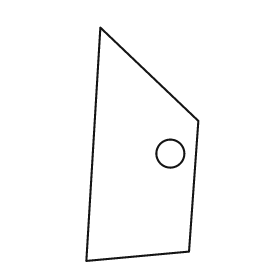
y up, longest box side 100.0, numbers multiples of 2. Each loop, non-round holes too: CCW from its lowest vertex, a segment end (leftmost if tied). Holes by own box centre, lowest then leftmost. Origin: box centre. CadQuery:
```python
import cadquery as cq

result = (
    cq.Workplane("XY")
    .moveTo(-24.0, -50.0)
    .lineTo(20.0, -46.0)
    .lineTo(24.0, 10.0)
    .lineTo(-18.0, 50.0)
    .close()
    .moveTo(12.0, -4.0)
    .circle(6.0)
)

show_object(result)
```